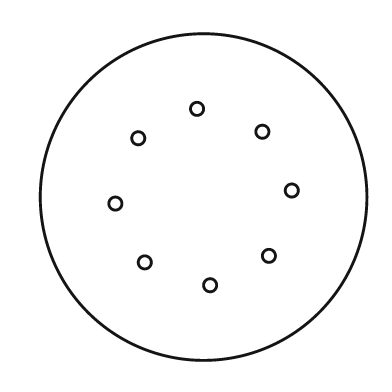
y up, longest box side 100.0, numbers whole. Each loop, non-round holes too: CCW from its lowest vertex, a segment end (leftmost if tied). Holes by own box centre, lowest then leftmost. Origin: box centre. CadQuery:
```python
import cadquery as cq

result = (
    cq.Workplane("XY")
    .moveTo(0.0, 0.0)
    .circle(50.0)
    .moveTo(2.0, -27.0)
    .circle(2.0)
    .moveTo(-18.0, -20.0)
    .circle(2.0)
    .moveTo(20.0, -18.0)
    .circle(2.0)
    .moveTo(-27.0, -2.0)
    .circle(2.0)
    .moveTo(27.0, 2.0)
    .circle(2.0)
    .moveTo(-20.0, 18.0)
    .circle(2.0)
    .moveTo(18.0, 20.0)
    .circle(2.0)
    .moveTo(-2.0, 27.0)
    .circle(2.0)
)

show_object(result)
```